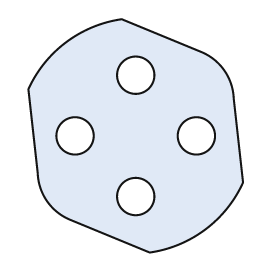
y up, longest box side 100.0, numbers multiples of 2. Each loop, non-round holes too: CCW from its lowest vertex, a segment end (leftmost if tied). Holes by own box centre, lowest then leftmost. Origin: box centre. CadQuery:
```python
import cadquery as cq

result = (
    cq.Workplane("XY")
    .moveTo(6.0, -50.0)
    .threePointArc((30.0, -40.0), (46.0, -20.0))
    .lineTo(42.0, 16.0)
    .threePointArc((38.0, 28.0), (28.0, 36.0))
    .lineTo(-6.0, 50.0)
    .threePointArc((-30.0, 40.0), (-46.0, 20.0))
    .lineTo(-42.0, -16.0)
    .threePointArc((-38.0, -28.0), (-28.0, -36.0))
    .close()
    .moveTo(0.0, -26.0)
    .circle(8.0)
    .moveTo(-26.0, 0.0)
    .circle(8.0)
    .moveTo(26.0, 0.0)
    .circle(8.0)
    .moveTo(0.0, 26.0)
    .circle(8.0)
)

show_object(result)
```